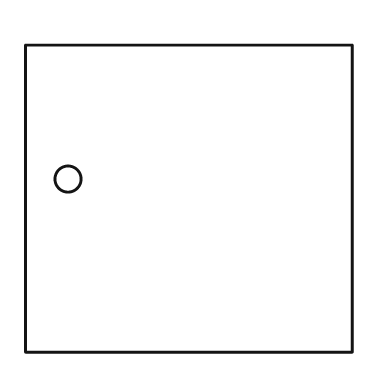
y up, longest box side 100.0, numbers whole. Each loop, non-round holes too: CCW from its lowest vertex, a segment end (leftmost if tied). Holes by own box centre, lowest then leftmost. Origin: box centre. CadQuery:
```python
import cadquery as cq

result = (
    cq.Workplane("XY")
    .moveTo(-50.0, -47.0)
    .lineTo(50.0, -47.0)
    .lineTo(50.0, 47.0)
    .lineTo(-50.0, 47.0)
    .close()
    .moveTo(-37.0, 6.0)
    .circle(4.0)
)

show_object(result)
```